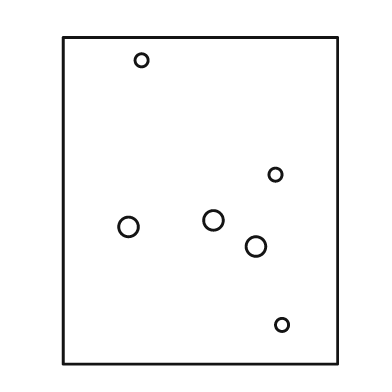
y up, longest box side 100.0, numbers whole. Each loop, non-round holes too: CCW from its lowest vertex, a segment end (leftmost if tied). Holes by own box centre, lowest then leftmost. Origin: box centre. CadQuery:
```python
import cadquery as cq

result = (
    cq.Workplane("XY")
    .moveTo(-42.0, -50.0)
    .lineTo(42.0, -50.0)
    .lineTo(42.0, 50.0)
    .lineTo(-42.0, 50.0)
    .close()
    .moveTo(25.0, -38.0)
    .circle(2.0)
    .moveTo(17.0, -14.0)
    .circle(3.0)
    .moveTo(-22.0, -8.0)
    .circle(3.0)
    .moveTo(4.0, -6.0)
    .circle(3.0)
    .moveTo(23.0, 8.0)
    .circle(2.0)
    .moveTo(-18.0, 43.0)
    .circle(2.0)
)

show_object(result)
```